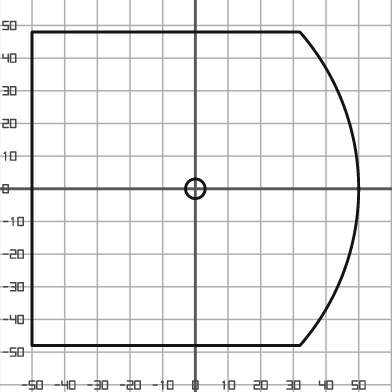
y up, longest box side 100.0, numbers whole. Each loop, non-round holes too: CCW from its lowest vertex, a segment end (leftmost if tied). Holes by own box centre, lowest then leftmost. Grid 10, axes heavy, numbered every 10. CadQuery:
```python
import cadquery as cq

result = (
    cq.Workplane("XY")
    .moveTo(-50.0, -48.0)
    .lineTo(32.0, -48.0)
    .threePointArc((50.0, 0.0), (32.0, 48.0))
    .lineTo(-50.0, 48.0)
    .close()
    .moveTo(0.0, 0.0)
    .circle(3.0)
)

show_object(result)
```